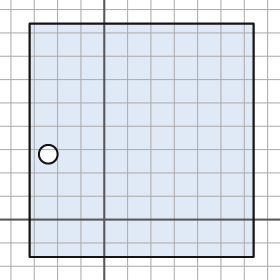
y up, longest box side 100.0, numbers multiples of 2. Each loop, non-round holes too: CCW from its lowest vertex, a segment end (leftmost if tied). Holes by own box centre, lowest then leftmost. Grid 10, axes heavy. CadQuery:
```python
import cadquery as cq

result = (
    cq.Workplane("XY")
    .moveTo(-32.0, -16.0)
    .lineTo(64.0, -16.0)
    .lineTo(64.0, 84.0)
    .lineTo(-32.0, 84.0)
    .close()
    .moveTo(-24.0, 28.0)
    .circle(4.0)
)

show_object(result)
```